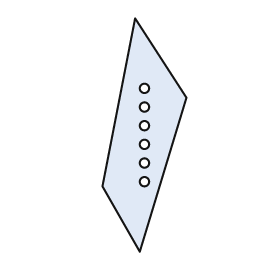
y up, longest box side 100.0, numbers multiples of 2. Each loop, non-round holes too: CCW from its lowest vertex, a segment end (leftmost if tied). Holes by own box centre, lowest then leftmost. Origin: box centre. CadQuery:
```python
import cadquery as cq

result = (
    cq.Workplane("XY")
    .moveTo(-2.0, -50.0)
    .lineTo(18.0, 16.0)
    .lineTo(-4.0, 50.0)
    .lineTo(-18.0, -22.0)
    .close()
    .moveTo(0.0, -20.0)
    .circle(2.0)
    .moveTo(0.0, -12.0)
    .circle(2.0)
    .moveTo(0.0, -4.0)
    .circle(2.0)
    .moveTo(0.0, 4.0)
    .circle(2.0)
    .moveTo(0.0, 12.0)
    .circle(2.0)
    .moveTo(0.0, 20.0)
    .circle(2.0)
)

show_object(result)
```